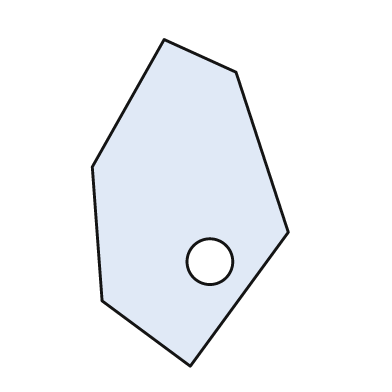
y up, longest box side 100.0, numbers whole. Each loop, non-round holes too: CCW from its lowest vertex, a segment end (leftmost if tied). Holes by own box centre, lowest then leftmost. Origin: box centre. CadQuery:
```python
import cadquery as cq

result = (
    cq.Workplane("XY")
    .moveTo(0.0, -50.0)
    .lineTo(30.0, -9.0)
    .lineTo(14.0, 40.0)
    .lineTo(-8.0, 50.0)
    .lineTo(-30.0, 11.0)
    .lineTo(-27.0, -30.0)
    .close()
    .moveTo(6.0, -18.0)
    .circle(7.0)
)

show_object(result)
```